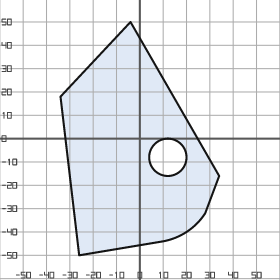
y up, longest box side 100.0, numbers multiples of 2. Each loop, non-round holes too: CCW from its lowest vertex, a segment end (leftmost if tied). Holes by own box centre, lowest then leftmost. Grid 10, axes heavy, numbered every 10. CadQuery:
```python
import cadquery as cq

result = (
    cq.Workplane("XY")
    .moveTo(-26.0, -50.0)
    .lineTo(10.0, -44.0)
    .threePointArc((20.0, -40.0), (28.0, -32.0))
    .lineTo(34.0, -16.0)
    .lineTo(-4.0, 50.0)
    .lineTo(-34.0, 18.0)
    .close()
    .moveTo(12.0, -8.0)
    .circle(8.0)
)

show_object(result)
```